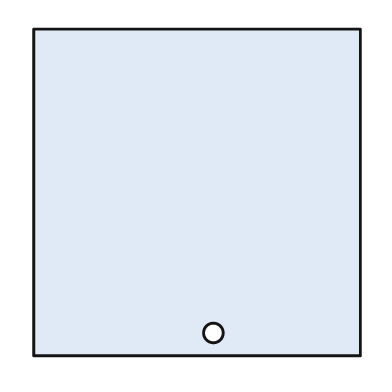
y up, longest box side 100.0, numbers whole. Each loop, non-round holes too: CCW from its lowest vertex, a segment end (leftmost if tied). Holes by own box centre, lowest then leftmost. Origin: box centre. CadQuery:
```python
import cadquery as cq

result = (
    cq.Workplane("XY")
    .moveTo(-50.0, -50.0)
    .lineTo(50.0, -50.0)
    .lineTo(50.0, 50.0)
    .lineTo(-50.0, 50.0)
    .close()
    .moveTo(5.0, -43.0)
    .circle(3.0)
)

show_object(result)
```